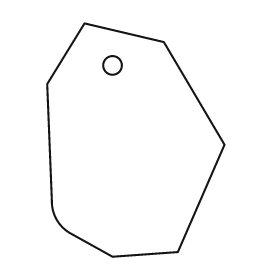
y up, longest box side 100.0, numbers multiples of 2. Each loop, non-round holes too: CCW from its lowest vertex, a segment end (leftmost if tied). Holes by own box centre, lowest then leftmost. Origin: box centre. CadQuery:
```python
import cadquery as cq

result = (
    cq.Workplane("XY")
    .moveTo(-10.0, -50.0)
    .lineTo(18.0, -48.0)
    .lineTo(38.0, -2.0)
    .lineTo(12.0, 42.0)
    .lineTo(-22.0, 50.0)
    .lineTo(-38.0, 24.0)
    .lineTo(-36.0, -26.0)
    .threePointArc((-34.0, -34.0), (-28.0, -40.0))
    .close()
    .moveTo(-10.0, 32.0)
    .circle(4.0)
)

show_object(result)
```